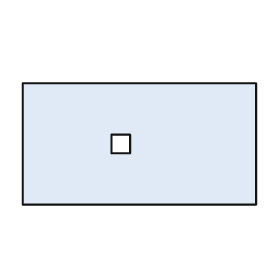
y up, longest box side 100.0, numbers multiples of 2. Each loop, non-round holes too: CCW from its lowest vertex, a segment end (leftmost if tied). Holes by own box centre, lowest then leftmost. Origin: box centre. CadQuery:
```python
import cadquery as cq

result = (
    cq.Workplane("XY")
    .moveTo(-50.0, -26.0)
    .lineTo(50.0, -26.0)
    .lineTo(50.0, 26.0)
    .lineTo(-50.0, 26.0)
    .close()
    .moveTo(-12.0, -4.0)
    .lineTo(-4.0, -4.0)
    .lineTo(-4.0, 4.0)
    .lineTo(-12.0, 4.0)
    .close()
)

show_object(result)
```